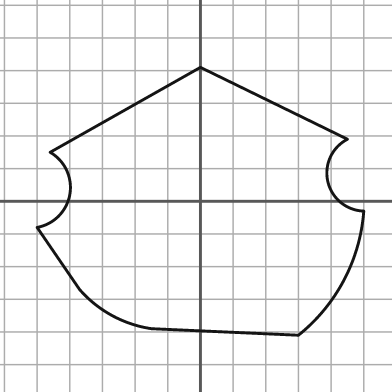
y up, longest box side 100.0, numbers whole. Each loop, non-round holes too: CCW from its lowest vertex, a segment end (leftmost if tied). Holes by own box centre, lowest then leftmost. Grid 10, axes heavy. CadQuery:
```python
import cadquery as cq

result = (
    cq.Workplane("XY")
    .moveTo(30.0, -41.0)
    .threePointArc((44.0, -24.0), (50.0, -3.0))
    .threePointArc((39.0, 6.0), (45.0, 19.0))
    .lineTo(0.0, 41.0)
    .lineTo(-46.0, 15.0)
    .threePointArc((-40.0, 2.0), (-50.0, -8.0))
    .lineTo(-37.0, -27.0)
    .threePointArc((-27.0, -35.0), (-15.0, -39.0))
    .close()
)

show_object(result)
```